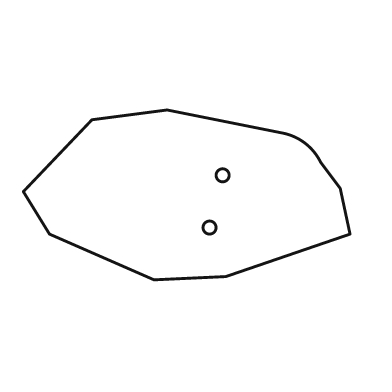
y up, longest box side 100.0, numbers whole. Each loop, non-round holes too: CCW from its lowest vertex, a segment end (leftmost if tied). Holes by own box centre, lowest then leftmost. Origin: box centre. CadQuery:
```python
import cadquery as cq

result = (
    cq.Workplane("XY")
    .moveTo(-10.0, -26.0)
    .lineTo(12.0, -25.0)
    .lineTo(50.0, -12.0)
    .lineTo(47.0, 2.0)
    .lineTo(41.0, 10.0)
    .threePointArc((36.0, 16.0), (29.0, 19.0))
    .lineTo(-6.0, 26.0)
    .lineTo(-29.0, 23.0)
    .lineTo(-50.0, 1.0)
    .lineTo(-42.0, -12.0)
    .close()
    .moveTo(7.0, -10.0)
    .circle(2.0)
    .moveTo(11.0, 6.0)
    .circle(2.0)
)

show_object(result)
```